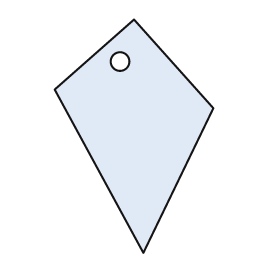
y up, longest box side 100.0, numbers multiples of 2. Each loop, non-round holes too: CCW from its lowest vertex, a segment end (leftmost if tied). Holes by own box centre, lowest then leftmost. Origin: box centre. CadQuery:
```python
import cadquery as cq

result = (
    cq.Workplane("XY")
    .moveTo(4.0, -50.0)
    .lineTo(34.0, 12.0)
    .lineTo(0.0, 50.0)
    .lineTo(-34.0, 20.0)
    .close()
    .moveTo(-6.0, 32.0)
    .circle(4.0)
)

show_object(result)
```